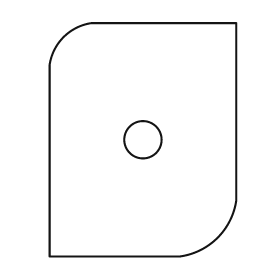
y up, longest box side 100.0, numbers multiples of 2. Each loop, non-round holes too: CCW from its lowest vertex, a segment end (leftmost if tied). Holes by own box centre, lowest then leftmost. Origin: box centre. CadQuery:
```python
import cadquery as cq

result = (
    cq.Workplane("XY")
    .moveTo(-40.0, -50.0)
    .lineTo(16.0, -50.0)
    .threePointArc((32.0, -42.0), (40.0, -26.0))
    .lineTo(40.0, 50.0)
    .lineTo(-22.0, 50.0)
    .threePointArc((-34.0, 44.0), (-40.0, 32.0))
    .close()
    .moveTo(0.0, 0.0)
    .circle(8.0)
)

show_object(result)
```